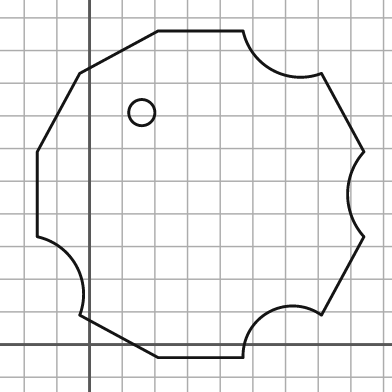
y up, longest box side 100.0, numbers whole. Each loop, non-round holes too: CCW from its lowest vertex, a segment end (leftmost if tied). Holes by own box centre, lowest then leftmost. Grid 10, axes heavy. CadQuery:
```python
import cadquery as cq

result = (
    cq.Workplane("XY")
    .moveTo(21.0, -4.0)
    .lineTo(47.0, -4.0)
    .threePointArc((55.0, 10.0), (71.0, 9.0))
    .lineTo(84.0, 33.0)
    .threePointArc((79.0, 46.0), (84.0, 59.0))
    .lineTo(71.0, 83.0)
    .threePointArc((56.0, 84.0), (47.0, 96.0))
    .lineTo(21.0, 96.0)
    .lineTo(-3.0, 83.0)
    .lineTo(-16.0, 59.0)
    .lineTo(-16.0, 33.0)
    .threePointArc((-4.0, 24.0), (-3.0, 9.0))
    .close()
    .moveTo(16.0, 71.0)
    .circle(4.0)
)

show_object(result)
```